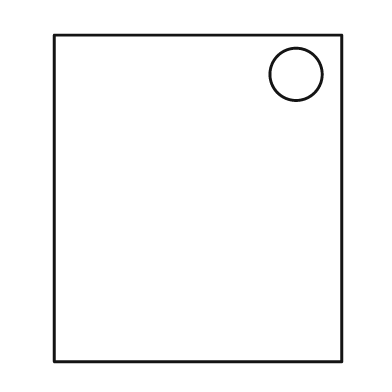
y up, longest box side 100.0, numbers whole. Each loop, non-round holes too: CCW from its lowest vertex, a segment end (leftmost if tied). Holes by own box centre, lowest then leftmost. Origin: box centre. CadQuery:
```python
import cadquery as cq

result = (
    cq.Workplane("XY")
    .moveTo(-44.0, -50.0)
    .lineTo(44.0, -50.0)
    .lineTo(44.0, 50.0)
    .lineTo(-44.0, 50.0)
    .close()
    .moveTo(30.0, 38.0)
    .circle(8.0)
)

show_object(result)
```